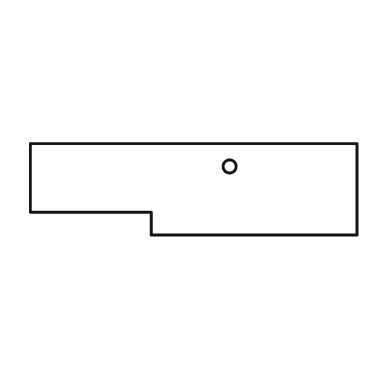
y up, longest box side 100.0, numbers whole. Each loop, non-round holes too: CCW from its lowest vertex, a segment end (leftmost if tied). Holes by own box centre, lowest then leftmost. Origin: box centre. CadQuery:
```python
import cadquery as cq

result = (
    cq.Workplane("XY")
    .moveTo(-13.0, -14.0)
    .lineTo(50.0, -14.0)
    .lineTo(50.0, 14.0)
    .lineTo(-50.0, 14.0)
    .lineTo(-50.0, -7.0)
    .lineTo(-13.0, -7.0)
    .close()
    .moveTo(11.0, 7.0)
    .circle(2.0)
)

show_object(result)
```